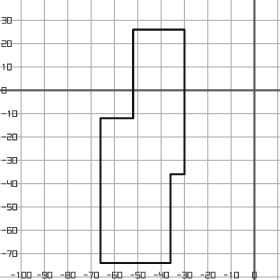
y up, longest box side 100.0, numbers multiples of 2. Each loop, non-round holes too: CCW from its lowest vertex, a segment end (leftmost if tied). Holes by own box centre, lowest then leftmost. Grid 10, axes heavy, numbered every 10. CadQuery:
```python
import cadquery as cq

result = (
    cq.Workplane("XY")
    .moveTo(-66.0, -74.0)
    .lineTo(-36.0, -74.0)
    .lineTo(-36.0, -36.0)
    .lineTo(-30.0, -36.0)
    .lineTo(-30.0, 26.0)
    .lineTo(-52.0, 26.0)
    .lineTo(-52.0, -12.0)
    .lineTo(-66.0, -12.0)
    .close()
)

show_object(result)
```